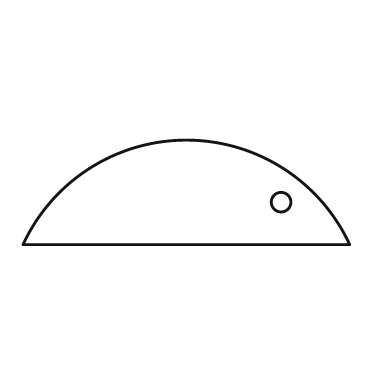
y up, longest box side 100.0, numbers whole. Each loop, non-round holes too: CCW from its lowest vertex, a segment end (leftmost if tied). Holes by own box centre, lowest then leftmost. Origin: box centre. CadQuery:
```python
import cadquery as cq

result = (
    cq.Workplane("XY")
    .moveTo(-50.0, -16.0)
    .lineTo(50.0, -16.0)
    .threePointArc((0.0, 16.0), (-50.0, -16.0))
    .close()
    .moveTo(29.0, -3.0)
    .circle(3.0)
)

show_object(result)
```